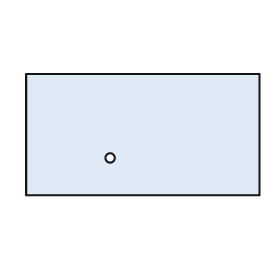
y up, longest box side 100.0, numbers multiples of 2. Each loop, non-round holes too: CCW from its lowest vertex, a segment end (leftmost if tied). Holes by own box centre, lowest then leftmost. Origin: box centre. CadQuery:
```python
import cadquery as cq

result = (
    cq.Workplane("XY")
    .moveTo(-50.0, -26.0)
    .lineTo(50.0, -26.0)
    .lineTo(50.0, 26.0)
    .lineTo(-50.0, 26.0)
    .close()
    .moveTo(-14.0, -10.0)
    .circle(2.0)
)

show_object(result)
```